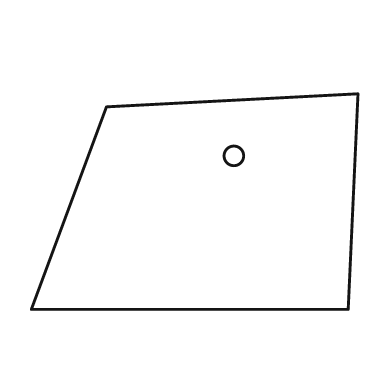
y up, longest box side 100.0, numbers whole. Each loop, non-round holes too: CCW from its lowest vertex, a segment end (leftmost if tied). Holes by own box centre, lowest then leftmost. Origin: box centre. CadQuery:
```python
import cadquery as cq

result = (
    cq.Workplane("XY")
    .moveTo(-50.0, -33.0)
    .lineTo(47.0, -33.0)
    .lineTo(50.0, 33.0)
    .lineTo(-27.0, 29.0)
    .close()
    .moveTo(12.0, 14.0)
    .circle(3.0)
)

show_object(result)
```